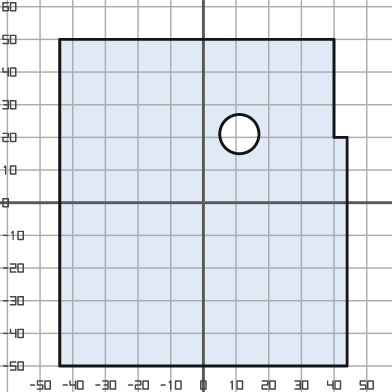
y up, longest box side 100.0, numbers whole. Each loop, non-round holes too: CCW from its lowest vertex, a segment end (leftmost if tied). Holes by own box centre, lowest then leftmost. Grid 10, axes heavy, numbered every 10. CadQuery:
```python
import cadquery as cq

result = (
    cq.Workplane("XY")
    .moveTo(-44.0, -50.0)
    .lineTo(44.0, -50.0)
    .lineTo(44.0, 20.0)
    .lineTo(40.0, 20.0)
    .lineTo(40.0, 50.0)
    .lineTo(-44.0, 50.0)
    .close()
    .moveTo(11.0, 21.0)
    .circle(6.0)
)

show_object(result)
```